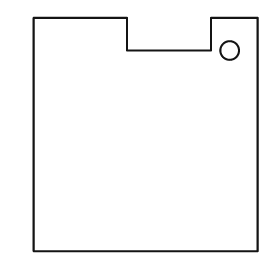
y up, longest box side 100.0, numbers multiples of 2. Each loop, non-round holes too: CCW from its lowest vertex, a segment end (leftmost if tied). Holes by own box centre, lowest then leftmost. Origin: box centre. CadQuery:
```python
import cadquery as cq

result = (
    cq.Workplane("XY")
    .moveTo(-48.0, -50.0)
    .lineTo(48.0, -50.0)
    .lineTo(48.0, 50.0)
    .lineTo(28.0, 50.0)
    .lineTo(28.0, 36.0)
    .lineTo(-8.0, 36.0)
    .lineTo(-8.0, 50.0)
    .lineTo(-48.0, 50.0)
    .close()
    .moveTo(36.0, 36.0)
    .circle(4.0)
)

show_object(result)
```